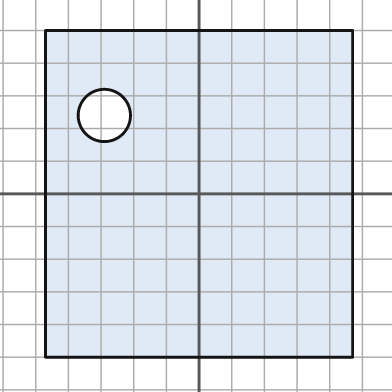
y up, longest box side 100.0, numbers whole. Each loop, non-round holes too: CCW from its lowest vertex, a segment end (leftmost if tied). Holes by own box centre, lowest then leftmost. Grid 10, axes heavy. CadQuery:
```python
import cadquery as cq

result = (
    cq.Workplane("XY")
    .moveTo(-47.0, -50.0)
    .lineTo(47.0, -50.0)
    .lineTo(47.0, 50.0)
    .lineTo(-47.0, 50.0)
    .close()
    .moveTo(-29.0, 24.0)
    .circle(8.0)
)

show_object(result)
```